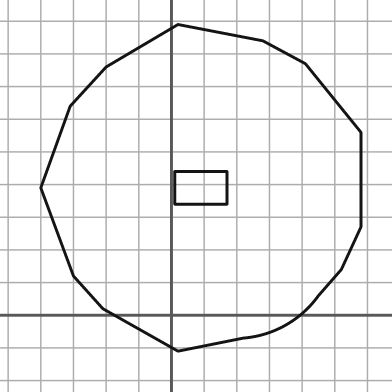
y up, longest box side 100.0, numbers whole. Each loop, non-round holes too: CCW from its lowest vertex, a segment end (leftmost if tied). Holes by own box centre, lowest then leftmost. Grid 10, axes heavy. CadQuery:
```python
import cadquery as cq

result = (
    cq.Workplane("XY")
    .moveTo(2.0, -11.0)
    .lineTo(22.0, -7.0)
    .threePointArc((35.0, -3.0), (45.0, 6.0))
    .lineTo(52.0, 14.0)
    .lineTo(58.0, 27.0)
    .lineTo(58.0, 56.0)
    .lineTo(41.0, 77.0)
    .lineTo(28.0, 84.0)
    .lineTo(2.0, 89.0)
    .lineTo(-20.0, 76.0)
    .lineTo(-31.0, 64.0)
    .lineTo(-40.0, 39.0)
    .lineTo(-30.0, 12.0)
    .lineTo(-21.0, 2.0)
    .close()
    .moveTo(1.0, 34.0)
    .lineTo(17.0, 34.0)
    .lineTo(17.0, 44.0)
    .lineTo(1.0, 44.0)
    .close()
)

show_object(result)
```